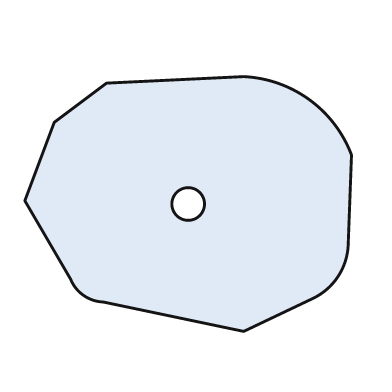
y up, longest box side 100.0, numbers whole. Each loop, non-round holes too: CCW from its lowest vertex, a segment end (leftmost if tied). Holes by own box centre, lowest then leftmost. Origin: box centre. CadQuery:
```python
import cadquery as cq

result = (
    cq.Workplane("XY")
    .moveTo(17.0, -39.0)
    .lineTo(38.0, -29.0)
    .threePointArc((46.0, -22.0), (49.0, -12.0))
    .lineTo(50.0, 15.0)
    .threePointArc((37.0, 32.0), (17.0, 39.0))
    .lineTo(-25.0, 37.0)
    .lineTo(-41.0, 25.0)
    .lineTo(-50.0, 1.0)
    .lineTo(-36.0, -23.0)
    .threePointArc((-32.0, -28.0), (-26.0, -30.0))
    .close()
    .moveTo(0.0, 0.0)
    .circle(5.0)
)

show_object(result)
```